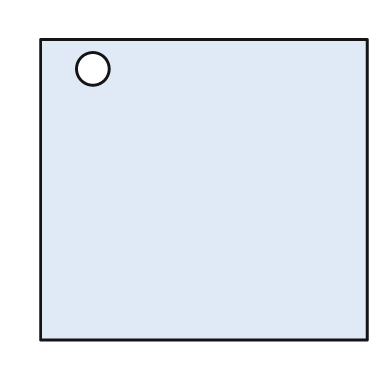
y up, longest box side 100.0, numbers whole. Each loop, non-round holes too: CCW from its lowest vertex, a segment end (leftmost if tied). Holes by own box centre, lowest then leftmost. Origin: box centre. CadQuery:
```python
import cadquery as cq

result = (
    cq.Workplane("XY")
    .moveTo(-50.0, -46.0)
    .lineTo(50.0, -46.0)
    .lineTo(50.0, 46.0)
    .lineTo(-50.0, 46.0)
    .close()
    .moveTo(-34.0, 37.0)
    .circle(5.0)
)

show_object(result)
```